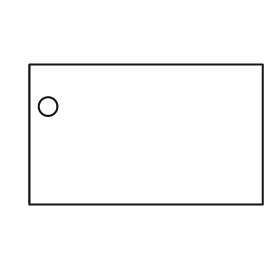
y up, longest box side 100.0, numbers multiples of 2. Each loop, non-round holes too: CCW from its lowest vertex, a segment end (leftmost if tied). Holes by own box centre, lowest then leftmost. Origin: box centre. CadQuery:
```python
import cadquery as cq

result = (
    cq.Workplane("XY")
    .moveTo(-50.0, -30.0)
    .lineTo(50.0, -30.0)
    .lineTo(50.0, 30.0)
    .lineTo(-50.0, 30.0)
    .close()
    .moveTo(-42.0, 12.0)
    .circle(4.0)
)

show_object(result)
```